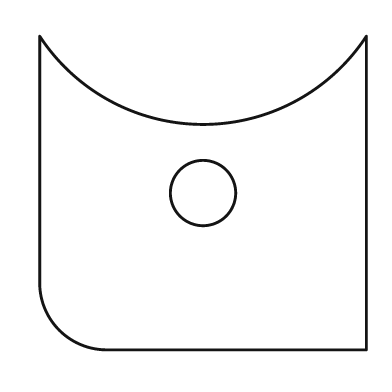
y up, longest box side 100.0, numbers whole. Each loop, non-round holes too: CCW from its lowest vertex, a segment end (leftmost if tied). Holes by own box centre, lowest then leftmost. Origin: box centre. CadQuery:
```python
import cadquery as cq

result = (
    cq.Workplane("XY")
    .moveTo(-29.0, -48.0)
    .lineTo(50.0, -48.0)
    .lineTo(50.0, 48.0)
    .threePointArc((0.0, 21.0), (-50.0, 48.0))
    .lineTo(-50.0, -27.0)
    .threePointArc((-44.0, -42.0), (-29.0, -48.0))
    .close()
    .moveTo(0.0, 0.0)
    .circle(10.0)
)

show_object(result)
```